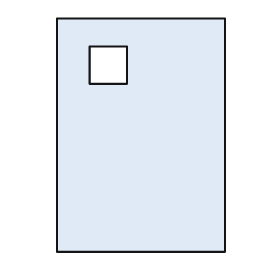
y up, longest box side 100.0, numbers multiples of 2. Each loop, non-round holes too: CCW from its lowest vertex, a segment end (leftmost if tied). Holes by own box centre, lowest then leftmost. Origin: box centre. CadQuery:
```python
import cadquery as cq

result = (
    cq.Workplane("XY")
    .moveTo(-36.0, -50.0)
    .lineTo(36.0, -50.0)
    .lineTo(36.0, 50.0)
    .lineTo(-36.0, 50.0)
    .close()
    .moveTo(-22.0, 22.0)
    .lineTo(-6.0, 22.0)
    .lineTo(-6.0, 38.0)
    .lineTo(-22.0, 38.0)
    .close()
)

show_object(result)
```